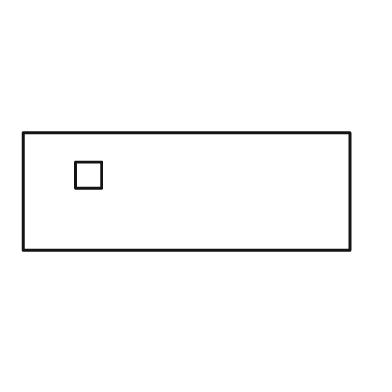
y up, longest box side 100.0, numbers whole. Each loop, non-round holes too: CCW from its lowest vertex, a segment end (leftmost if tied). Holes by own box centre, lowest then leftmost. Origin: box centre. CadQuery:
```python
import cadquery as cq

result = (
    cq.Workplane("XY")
    .moveTo(-50.0, -18.0)
    .lineTo(50.0, -18.0)
    .lineTo(50.0, 18.0)
    .lineTo(-50.0, 18.0)
    .close()
    .moveTo(-34.0, 1.0)
    .lineTo(-26.0, 1.0)
    .lineTo(-26.0, 9.0)
    .lineTo(-34.0, 9.0)
    .close()
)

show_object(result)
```